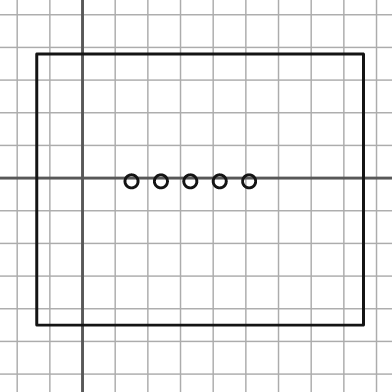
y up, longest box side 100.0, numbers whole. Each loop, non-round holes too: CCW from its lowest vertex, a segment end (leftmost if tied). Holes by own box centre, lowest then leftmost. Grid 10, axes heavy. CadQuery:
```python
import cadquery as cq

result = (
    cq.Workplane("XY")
    .moveTo(-14.0, -45.0)
    .lineTo(86.0, -45.0)
    .lineTo(86.0, 38.0)
    .lineTo(-14.0, 38.0)
    .close()
    .moveTo(15.0, -1.0)
    .circle(2.0)
    .moveTo(24.0, -1.0)
    .circle(2.0)
    .moveTo(33.0, -1.0)
    .circle(2.0)
    .moveTo(42.0, -1.0)
    .circle(2.0)
    .moveTo(51.0, -1.0)
    .circle(2.0)
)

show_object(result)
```